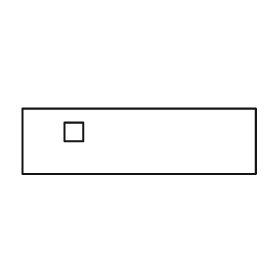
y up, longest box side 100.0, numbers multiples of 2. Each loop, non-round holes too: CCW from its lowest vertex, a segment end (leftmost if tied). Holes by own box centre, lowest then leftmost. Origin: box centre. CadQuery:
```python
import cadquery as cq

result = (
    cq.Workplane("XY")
    .moveTo(-50.0, -14.0)
    .lineTo(50.0, -14.0)
    .lineTo(50.0, 14.0)
    .lineTo(-50.0, 14.0)
    .close()
    .moveTo(-32.0, 0.0)
    .lineTo(-24.0, 0.0)
    .lineTo(-24.0, 8.0)
    .lineTo(-32.0, 8.0)
    .close()
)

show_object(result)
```